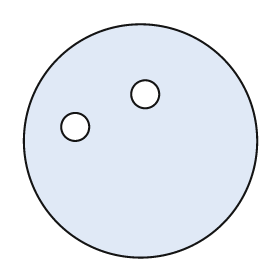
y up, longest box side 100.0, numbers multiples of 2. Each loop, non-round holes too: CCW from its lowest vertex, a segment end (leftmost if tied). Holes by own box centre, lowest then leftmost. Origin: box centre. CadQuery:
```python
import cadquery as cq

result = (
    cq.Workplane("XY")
    .moveTo(0.0, 0.0)
    .circle(50.0)
    .moveTo(-28.0, 6.0)
    .circle(6.0)
    .moveTo(2.0, 20.0)
    .circle(6.0)
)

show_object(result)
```